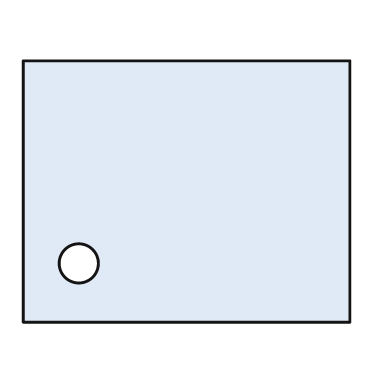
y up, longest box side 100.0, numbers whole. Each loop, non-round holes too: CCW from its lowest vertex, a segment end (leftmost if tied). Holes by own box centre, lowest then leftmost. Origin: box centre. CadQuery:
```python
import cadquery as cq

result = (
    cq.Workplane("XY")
    .moveTo(-50.0, -40.0)
    .lineTo(50.0, -40.0)
    .lineTo(50.0, 40.0)
    .lineTo(-50.0, 40.0)
    .close()
    .moveTo(-33.0, -22.0)
    .circle(6.0)
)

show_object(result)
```